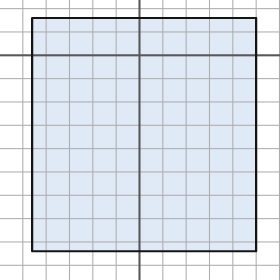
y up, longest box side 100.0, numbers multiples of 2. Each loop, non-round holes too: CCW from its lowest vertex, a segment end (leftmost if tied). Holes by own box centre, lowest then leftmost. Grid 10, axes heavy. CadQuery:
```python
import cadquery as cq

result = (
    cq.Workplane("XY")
    .moveTo(-46.0, -84.0)
    .lineTo(50.0, -84.0)
    .lineTo(50.0, 16.0)
    .lineTo(-46.0, 16.0)
    .close()
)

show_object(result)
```